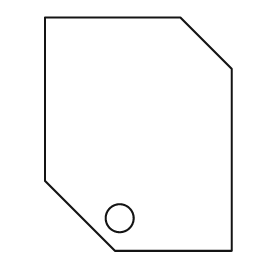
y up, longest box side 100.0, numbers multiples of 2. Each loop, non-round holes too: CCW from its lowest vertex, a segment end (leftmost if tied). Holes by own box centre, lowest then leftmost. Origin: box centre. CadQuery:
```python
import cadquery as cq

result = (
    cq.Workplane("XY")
    .moveTo(-10.0, -50.0)
    .lineTo(40.0, -50.0)
    .lineTo(40.0, 28.0)
    .lineTo(18.0, 50.0)
    .lineTo(-40.0, 50.0)
    .lineTo(-40.0, -20.0)
    .close()
    .moveTo(-8.0, -36.0)
    .circle(6.0)
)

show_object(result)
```